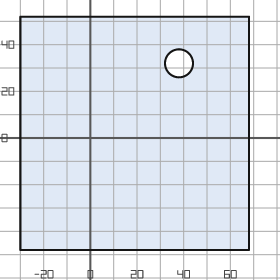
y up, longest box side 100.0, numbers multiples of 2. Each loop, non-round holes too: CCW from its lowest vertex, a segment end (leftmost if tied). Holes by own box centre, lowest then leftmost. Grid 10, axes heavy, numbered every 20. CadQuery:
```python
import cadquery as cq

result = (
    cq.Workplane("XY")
    .moveTo(-30.0, -48.0)
    .lineTo(68.0, -48.0)
    .lineTo(68.0, 52.0)
    .lineTo(-30.0, 52.0)
    .close()
    .moveTo(38.0, 32.0)
    .circle(6.0)
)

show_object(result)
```